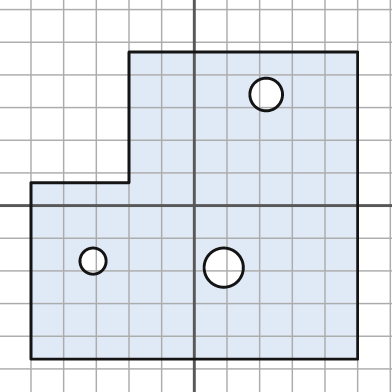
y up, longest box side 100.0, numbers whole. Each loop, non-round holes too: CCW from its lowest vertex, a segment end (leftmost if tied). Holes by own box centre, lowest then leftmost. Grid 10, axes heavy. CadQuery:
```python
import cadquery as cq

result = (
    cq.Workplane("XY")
    .moveTo(-50.0, -47.0)
    .lineTo(50.0, -47.0)
    .lineTo(50.0, 47.0)
    .lineTo(-20.0, 47.0)
    .lineTo(-20.0, 7.0)
    .lineTo(-50.0, 7.0)
    .close()
    .moveTo(9.0, -19.0)
    .circle(6.0)
    .moveTo(-31.0, -17.0)
    .circle(4.0)
    .moveTo(22.0, 34.0)
    .circle(5.0)
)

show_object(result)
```